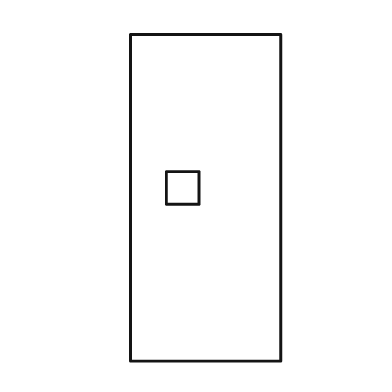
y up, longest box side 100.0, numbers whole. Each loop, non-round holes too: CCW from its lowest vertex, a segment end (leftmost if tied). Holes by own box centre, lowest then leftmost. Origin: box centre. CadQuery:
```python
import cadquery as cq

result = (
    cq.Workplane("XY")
    .moveTo(-23.0, -50.0)
    .lineTo(23.0, -50.0)
    .lineTo(23.0, 50.0)
    .lineTo(-23.0, 50.0)
    .close()
    .moveTo(-12.0, -2.0)
    .lineTo(-2.0, -2.0)
    .lineTo(-2.0, 8.0)
    .lineTo(-12.0, 8.0)
    .close()
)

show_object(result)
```